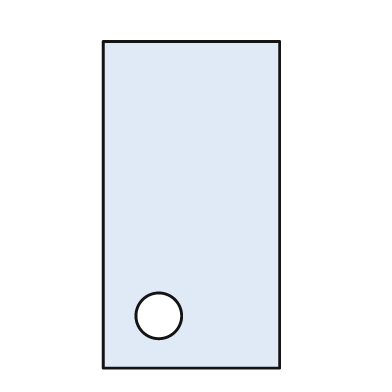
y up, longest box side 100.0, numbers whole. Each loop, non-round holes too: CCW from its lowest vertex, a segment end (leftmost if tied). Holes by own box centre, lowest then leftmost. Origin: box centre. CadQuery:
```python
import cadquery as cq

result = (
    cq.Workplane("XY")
    .moveTo(-27.0, -50.0)
    .lineTo(27.0, -50.0)
    .lineTo(27.0, 50.0)
    .lineTo(-27.0, 50.0)
    .close()
    .moveTo(-10.0, -34.0)
    .circle(7.0)
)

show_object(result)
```